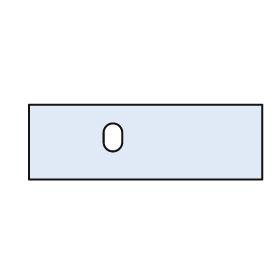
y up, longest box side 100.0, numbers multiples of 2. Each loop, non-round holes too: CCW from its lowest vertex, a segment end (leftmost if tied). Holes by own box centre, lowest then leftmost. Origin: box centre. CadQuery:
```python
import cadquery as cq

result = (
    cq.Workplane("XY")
    .moveTo(-50.0, -16.0)
    .lineTo(50.0, -16.0)
    .lineTo(50.0, 16.0)
    .lineTo(-50.0, 16.0)
    .close()
    .moveTo(-18.0, 0.0)
    .threePointArc((-14.0, -4.0), (-10.0, 0.0))
    .lineTo(-10.0, 4.0)
    .threePointArc((-14.0, 8.0), (-18.0, 4.0))
    .close()
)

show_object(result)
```